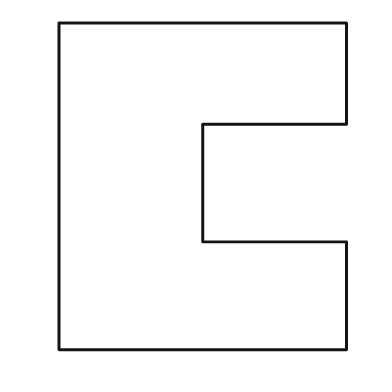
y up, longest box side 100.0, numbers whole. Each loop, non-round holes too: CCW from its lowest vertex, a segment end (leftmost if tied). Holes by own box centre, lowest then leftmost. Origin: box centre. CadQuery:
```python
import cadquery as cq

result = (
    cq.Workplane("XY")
    .moveTo(-44.0, -50.0)
    .lineTo(44.0, -50.0)
    .lineTo(44.0, -17.0)
    .lineTo(0.0, -17.0)
    .lineTo(0.0, 19.0)
    .lineTo(44.0, 19.0)
    .lineTo(44.0, 50.0)
    .lineTo(-44.0, 50.0)
    .close()
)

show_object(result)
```